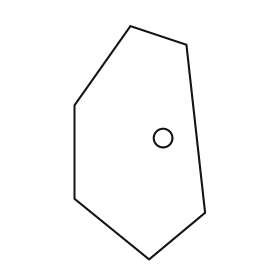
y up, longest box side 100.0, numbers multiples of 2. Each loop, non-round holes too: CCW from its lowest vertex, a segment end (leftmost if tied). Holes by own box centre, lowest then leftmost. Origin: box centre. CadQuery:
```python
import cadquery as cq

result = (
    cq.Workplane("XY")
    .moveTo(4.0, -50.0)
    .lineTo(28.0, -30.0)
    .lineTo(20.0, 42.0)
    .lineTo(-4.0, 50.0)
    .lineTo(-28.0, 16.0)
    .lineTo(-28.0, -24.0)
    .close()
    .moveTo(10.0, 2.0)
    .circle(4.0)
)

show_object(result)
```